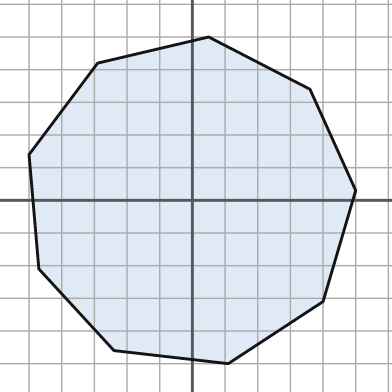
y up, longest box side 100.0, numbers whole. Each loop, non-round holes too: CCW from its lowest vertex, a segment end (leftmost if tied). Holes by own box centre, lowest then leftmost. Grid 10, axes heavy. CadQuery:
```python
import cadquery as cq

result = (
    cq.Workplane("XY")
    .moveTo(11.0, -50.0)
    .lineTo(40.0, -31.0)
    .lineTo(50.0, 3.0)
    .lineTo(36.0, 34.0)
    .lineTo(5.0, 50.0)
    .lineTo(-29.0, 42.0)
    .lineTo(-50.0, 14.0)
    .lineTo(-47.0, -21.0)
    .lineTo(-24.0, -46.0)
    .close()
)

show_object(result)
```